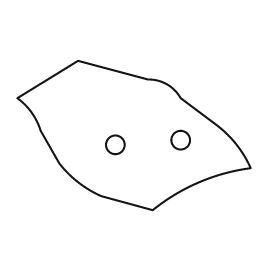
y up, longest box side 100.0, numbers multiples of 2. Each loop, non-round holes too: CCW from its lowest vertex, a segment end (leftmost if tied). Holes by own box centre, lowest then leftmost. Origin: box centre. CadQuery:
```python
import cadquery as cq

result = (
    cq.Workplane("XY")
    .moveTo(8.0, -32.0)
    .threePointArc((28.0, -20.0), (50.0, -14.0))
    .threePointArc((44.0, -4.0), (36.0, 4.0))
    .lineTo(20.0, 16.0)
    .threePointArc((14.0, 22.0), (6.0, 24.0))
    .lineTo(-24.0, 32.0)
    .lineTo(-50.0, 16.0)
    .threePointArc((-44.0, 10.0), (-40.0, 2.0))
    .lineTo(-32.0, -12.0)
    .threePointArc((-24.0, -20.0), (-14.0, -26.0))
    .close()
    .moveTo(-8.0, -4.0)
    .circle(4.0)
    .moveTo(20.0, -2.0)
    .circle(4.0)
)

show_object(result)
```